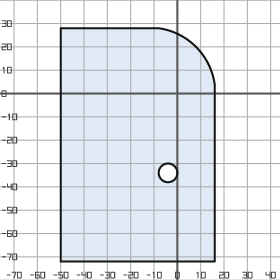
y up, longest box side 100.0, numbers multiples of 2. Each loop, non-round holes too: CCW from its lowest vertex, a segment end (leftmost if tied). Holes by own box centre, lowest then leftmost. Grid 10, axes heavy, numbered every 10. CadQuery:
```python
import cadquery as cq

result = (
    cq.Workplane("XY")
    .moveTo(-50.0, -72.0)
    .lineTo(16.0, -72.0)
    .lineTo(16.0, 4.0)
    .threePointArc((8.0, 20.0), (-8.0, 28.0))
    .lineTo(-50.0, 28.0)
    .close()
    .moveTo(-4.0, -34.0)
    .circle(4.0)
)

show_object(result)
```